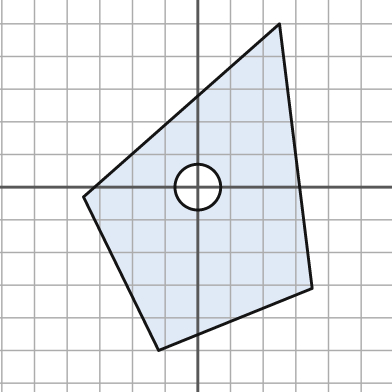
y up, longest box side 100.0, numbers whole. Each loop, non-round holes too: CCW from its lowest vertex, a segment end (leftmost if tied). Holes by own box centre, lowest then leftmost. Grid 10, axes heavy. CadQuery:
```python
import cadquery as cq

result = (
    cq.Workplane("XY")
    .moveTo(-12.0, -50.0)
    .lineTo(35.0, -31.0)
    .lineTo(25.0, 50.0)
    .lineTo(-35.0, -3.0)
    .close()
    .moveTo(0.0, 0.0)
    .circle(7.0)
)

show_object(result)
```